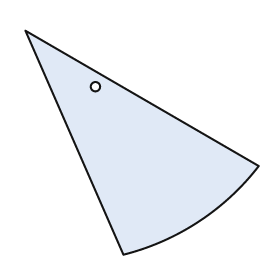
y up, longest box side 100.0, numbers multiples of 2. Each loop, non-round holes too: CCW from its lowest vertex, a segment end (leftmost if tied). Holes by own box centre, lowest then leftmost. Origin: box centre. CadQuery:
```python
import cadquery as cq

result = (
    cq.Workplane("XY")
    .moveTo(-8.0, -48.0)
    .threePointArc((24.0, -34.0), (50.0, -10.0))
    .lineTo(-50.0, 48.0)
    .close()
    .moveTo(-20.0, 24.0)
    .circle(2.0)
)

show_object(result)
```